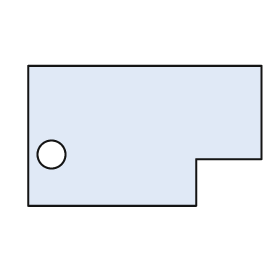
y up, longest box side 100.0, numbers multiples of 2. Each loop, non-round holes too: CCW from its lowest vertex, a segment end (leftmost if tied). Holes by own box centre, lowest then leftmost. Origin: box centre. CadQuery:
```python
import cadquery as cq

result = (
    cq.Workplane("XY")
    .moveTo(-50.0, -30.0)
    .lineTo(22.0, -30.0)
    .lineTo(22.0, -10.0)
    .lineTo(50.0, -10.0)
    .lineTo(50.0, 30.0)
    .lineTo(-50.0, 30.0)
    .close()
    .moveTo(-40.0, -8.0)
    .circle(6.0)
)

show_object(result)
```